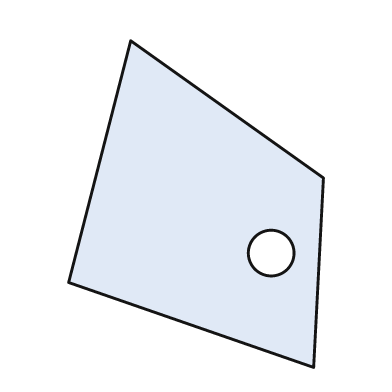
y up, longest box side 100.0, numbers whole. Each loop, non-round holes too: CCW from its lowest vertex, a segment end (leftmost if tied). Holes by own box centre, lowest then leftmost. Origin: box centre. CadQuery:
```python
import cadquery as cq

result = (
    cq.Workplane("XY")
    .moveTo(36.0, -50.0)
    .lineTo(39.0, 8.0)
    .lineTo(-20.0, 50.0)
    .lineTo(-39.0, -24.0)
    .close()
    .moveTo(23.0, -15.0)
    .circle(7.0)
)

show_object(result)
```